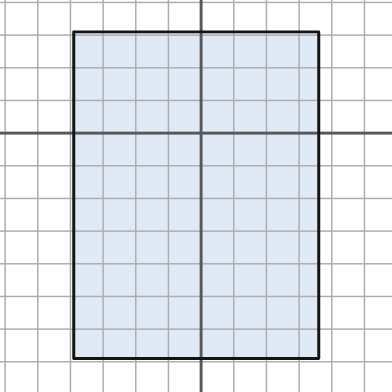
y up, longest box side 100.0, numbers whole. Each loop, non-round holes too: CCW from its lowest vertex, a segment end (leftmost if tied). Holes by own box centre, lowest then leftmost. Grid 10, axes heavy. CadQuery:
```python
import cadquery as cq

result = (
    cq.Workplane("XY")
    .moveTo(-39.0, -69.0)
    .lineTo(36.0, -69.0)
    .lineTo(36.0, 31.0)
    .lineTo(-39.0, 31.0)
    .close()
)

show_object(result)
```